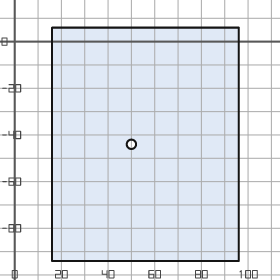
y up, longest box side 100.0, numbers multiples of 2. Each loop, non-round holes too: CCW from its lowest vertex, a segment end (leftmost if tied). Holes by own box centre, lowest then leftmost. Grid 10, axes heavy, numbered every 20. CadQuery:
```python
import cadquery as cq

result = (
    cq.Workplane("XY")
    .moveTo(16.0, -94.0)
    .lineTo(96.0, -94.0)
    .lineTo(96.0, 6.0)
    .lineTo(16.0, 6.0)
    .close()
    .moveTo(50.0, -44.0)
    .circle(2.0)
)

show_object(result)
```